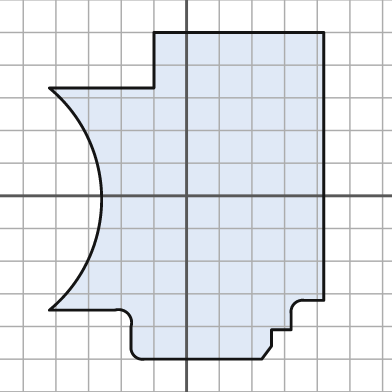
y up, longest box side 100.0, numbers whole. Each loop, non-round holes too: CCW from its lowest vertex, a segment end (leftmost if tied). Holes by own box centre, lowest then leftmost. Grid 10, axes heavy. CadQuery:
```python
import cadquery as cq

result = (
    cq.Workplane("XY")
    .moveTo(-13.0, -50.0)
    .lineTo(23.0, -50.0)
    .lineTo(26.0, -46.0)
    .lineTo(26.0, -41.0)
    .lineTo(32.0, -41.0)
    .lineTo(32.0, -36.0)
    .threePointArc((33.0, -33.0), (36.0, -32.0))
    .lineTo(42.0, -32.0)
    .lineTo(42.0, 50.0)
    .lineTo(-10.0, 50.0)
    .lineTo(-10.0, 33.0)
    .lineTo(-42.0, 33.0)
    .threePointArc((-26.0, -1.0), (-42.0, -35.0))
    .lineTo(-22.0, -35.0)
    .threePointArc((-18.0, -36.0), (-17.0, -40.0))
    .lineTo(-17.0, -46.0)
    .threePointArc((-16.0, -49.0), (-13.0, -50.0))
    .close()
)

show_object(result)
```